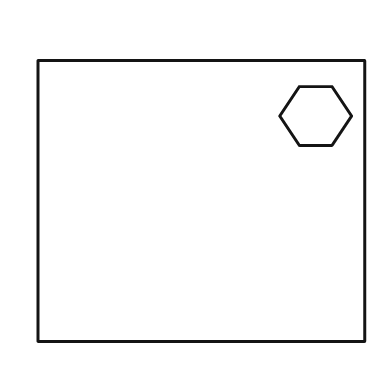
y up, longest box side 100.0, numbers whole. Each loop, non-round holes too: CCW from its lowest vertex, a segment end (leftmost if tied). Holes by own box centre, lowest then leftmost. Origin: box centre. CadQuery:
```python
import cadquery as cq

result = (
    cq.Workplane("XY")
    .moveTo(-50.0, -43.0)
    .lineTo(50.0, -43.0)
    .lineTo(50.0, 43.0)
    .lineTo(-50.0, 43.0)
    .close()
    .moveTo(30.0, 17.0)
    .lineTo(40.0, 17.0)
    .lineTo(46.0, 26.0)
    .lineTo(40.0, 35.0)
    .lineTo(30.0, 35.0)
    .lineTo(24.0, 26.0)
    .close()
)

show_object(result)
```